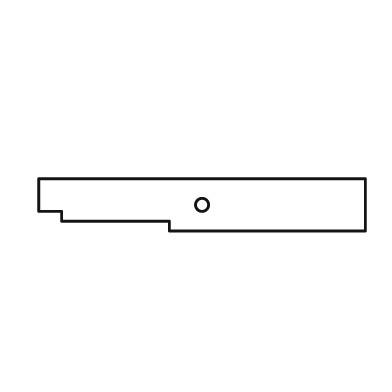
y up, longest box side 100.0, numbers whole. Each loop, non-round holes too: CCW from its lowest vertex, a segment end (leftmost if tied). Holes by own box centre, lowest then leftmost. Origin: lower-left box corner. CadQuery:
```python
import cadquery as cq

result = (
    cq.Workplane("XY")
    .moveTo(40.0, 0.0)
    .lineTo(100.0, 0.0)
    .lineTo(100.0, 16.0)
    .lineTo(0.0, 16.0)
    .lineTo(0.0, 6.0)
    .lineTo(7.0, 6.0)
    .lineTo(7.0, 3.0)
    .lineTo(40.0, 3.0)
    .close()
    .moveTo(50.0, 8.0)
    .circle(2.0)
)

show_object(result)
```